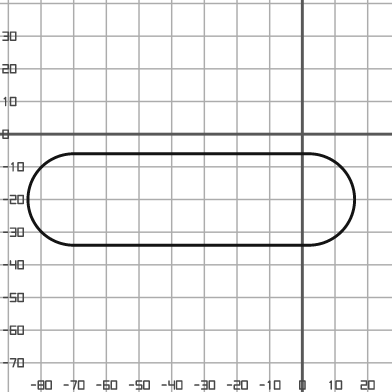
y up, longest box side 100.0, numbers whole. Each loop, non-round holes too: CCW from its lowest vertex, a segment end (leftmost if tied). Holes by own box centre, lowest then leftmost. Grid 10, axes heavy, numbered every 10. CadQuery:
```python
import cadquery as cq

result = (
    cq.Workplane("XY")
    .moveTo(-70.0, -34.0)
    .lineTo(2.0, -34.0)
    .threePointArc((16.0, -20.0), (2.0, -6.0))
    .lineTo(-70.0, -6.0)
    .threePointArc((-84.0, -20.0), (-70.0, -34.0))
    .close()
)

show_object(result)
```